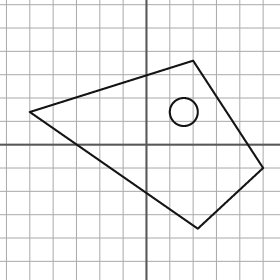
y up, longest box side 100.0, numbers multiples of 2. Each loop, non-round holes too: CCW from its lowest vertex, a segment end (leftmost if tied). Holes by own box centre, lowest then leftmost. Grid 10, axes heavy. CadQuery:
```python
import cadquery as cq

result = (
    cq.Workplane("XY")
    .moveTo(22.0, -36.0)
    .lineTo(50.0, -10.0)
    .lineTo(20.0, 36.0)
    .lineTo(-50.0, 14.0)
    .close()
    .moveTo(16.0, 14.0)
    .circle(6.0)
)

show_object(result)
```